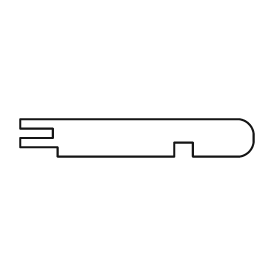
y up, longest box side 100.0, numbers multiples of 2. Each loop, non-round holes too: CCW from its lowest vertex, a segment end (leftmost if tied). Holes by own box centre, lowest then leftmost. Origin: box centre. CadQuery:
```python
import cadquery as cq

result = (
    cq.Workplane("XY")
    .moveTo(-34.0, -8.0)
    .lineTo(16.0, -8.0)
    .lineTo(16.0, -2.0)
    .lineTo(24.0, -2.0)
    .lineTo(24.0, -8.0)
    .lineTo(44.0, -8.0)
    .threePointArc((48.0, -6.0), (50.0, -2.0))
    .lineTo(50.0, 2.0)
    .threePointArc((48.0, 6.0), (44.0, 8.0))
    .lineTo(-50.0, 8.0)
    .lineTo(-50.0, 4.0)
    .lineTo(-36.0, 4.0)
    .lineTo(-36.0, 0.0)
    .lineTo(-50.0, 0.0)
    .lineTo(-50.0, -4.0)
    .lineTo(-34.0, -4.0)
    .close()
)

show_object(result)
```